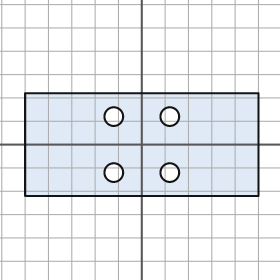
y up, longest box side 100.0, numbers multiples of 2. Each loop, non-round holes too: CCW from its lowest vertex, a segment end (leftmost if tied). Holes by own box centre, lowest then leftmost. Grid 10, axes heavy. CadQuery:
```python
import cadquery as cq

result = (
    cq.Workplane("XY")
    .moveTo(-50.0, -22.0)
    .lineTo(50.0, -22.0)
    .lineTo(50.0, 22.0)
    .lineTo(-50.0, 22.0)
    .close()
    .moveTo(-12.0, -12.0)
    .circle(4.0)
    .moveTo(12.0, -12.0)
    .circle(4.0)
    .moveTo(-12.0, 12.0)
    .circle(4.0)
    .moveTo(12.0, 12.0)
    .circle(4.0)
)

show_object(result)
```